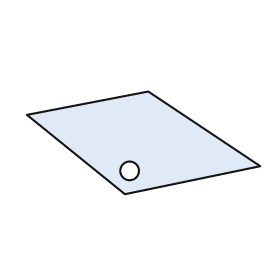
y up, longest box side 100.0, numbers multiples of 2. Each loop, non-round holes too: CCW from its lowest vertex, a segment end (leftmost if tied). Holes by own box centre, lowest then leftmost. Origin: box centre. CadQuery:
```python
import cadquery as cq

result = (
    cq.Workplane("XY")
    .moveTo(-8.0, -22.0)
    .lineTo(50.0, -10.0)
    .lineTo(2.0, 22.0)
    .lineTo(-50.0, 12.0)
    .close()
    .moveTo(-6.0, -12.0)
    .circle(4.0)
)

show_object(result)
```